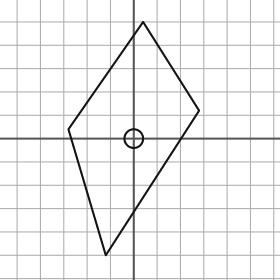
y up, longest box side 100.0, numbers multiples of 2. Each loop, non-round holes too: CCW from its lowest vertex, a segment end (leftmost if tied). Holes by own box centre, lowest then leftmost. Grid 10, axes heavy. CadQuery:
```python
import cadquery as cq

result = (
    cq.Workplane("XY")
    .moveTo(-12.0, -50.0)
    .lineTo(28.0, 12.0)
    .lineTo(4.0, 50.0)
    .lineTo(-28.0, 4.0)
    .close()
    .moveTo(0.0, 0.0)
    .circle(4.0)
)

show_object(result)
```